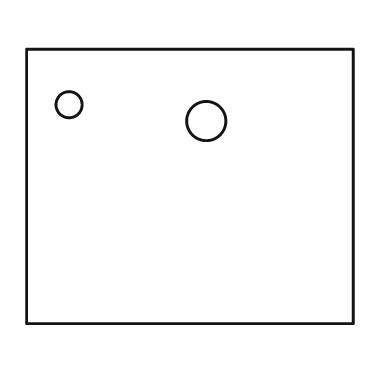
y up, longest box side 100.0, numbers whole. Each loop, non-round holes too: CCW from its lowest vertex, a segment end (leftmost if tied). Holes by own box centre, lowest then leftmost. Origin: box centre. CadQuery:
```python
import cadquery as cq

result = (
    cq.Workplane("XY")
    .moveTo(-50.0, -42.0)
    .lineTo(50.0, -42.0)
    .lineTo(50.0, 42.0)
    .lineTo(-50.0, 42.0)
    .close()
    .moveTo(5.0, 20.0)
    .circle(6.0)
    .moveTo(-37.0, 25.0)
    .circle(4.0)
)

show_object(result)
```